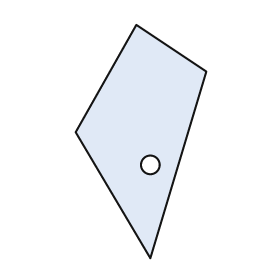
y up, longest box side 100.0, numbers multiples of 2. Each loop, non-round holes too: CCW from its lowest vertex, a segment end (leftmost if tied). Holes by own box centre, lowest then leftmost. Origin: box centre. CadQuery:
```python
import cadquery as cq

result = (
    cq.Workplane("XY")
    .moveTo(4.0, -50.0)
    .lineTo(28.0, 30.0)
    .lineTo(-2.0, 50.0)
    .lineTo(-28.0, 4.0)
    .close()
    .moveTo(4.0, -10.0)
    .circle(4.0)
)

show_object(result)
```